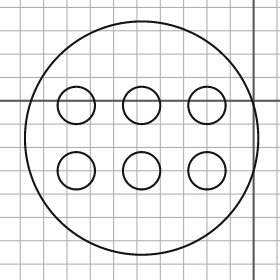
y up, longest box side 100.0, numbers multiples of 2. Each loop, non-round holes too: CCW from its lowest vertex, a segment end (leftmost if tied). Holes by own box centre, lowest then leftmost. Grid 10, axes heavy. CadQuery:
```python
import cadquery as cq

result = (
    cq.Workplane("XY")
    .moveTo(-48.0, -16.0)
    .circle(50.0)
    .moveTo(-76.0, -30.0)
    .circle(8.0)
    .moveTo(-48.0, -30.0)
    .circle(8.0)
    .moveTo(-20.0, -30.0)
    .circle(8.0)
    .moveTo(-76.0, -2.0)
    .circle(8.0)
    .moveTo(-48.0, -2.0)
    .circle(8.0)
    .moveTo(-20.0, -2.0)
    .circle(8.0)
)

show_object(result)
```